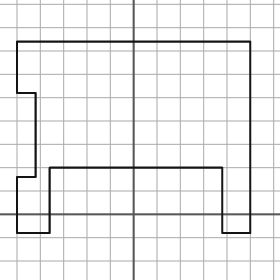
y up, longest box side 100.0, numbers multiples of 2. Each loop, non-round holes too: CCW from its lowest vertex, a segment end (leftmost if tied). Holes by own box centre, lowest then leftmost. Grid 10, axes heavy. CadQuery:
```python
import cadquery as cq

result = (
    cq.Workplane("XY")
    .moveTo(-50.0, -8.0)
    .lineTo(-36.0, -8.0)
    .lineTo(-36.0, 20.0)
    .lineTo(38.0, 20.0)
    .lineTo(38.0, -8.0)
    .lineTo(50.0, -8.0)
    .lineTo(50.0, 74.0)
    .lineTo(-50.0, 74.0)
    .lineTo(-50.0, 52.0)
    .lineTo(-42.0, 52.0)
    .lineTo(-42.0, 16.0)
    .lineTo(-50.0, 16.0)
    .close()
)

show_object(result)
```